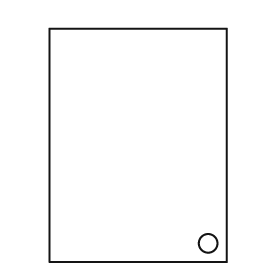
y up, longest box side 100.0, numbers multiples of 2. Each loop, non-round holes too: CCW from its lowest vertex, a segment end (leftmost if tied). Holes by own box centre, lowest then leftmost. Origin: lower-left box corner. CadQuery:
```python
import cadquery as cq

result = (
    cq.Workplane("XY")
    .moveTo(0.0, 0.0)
    .lineTo(76.0, 0.0)
    .lineTo(76.0, 100.0)
    .lineTo(0.0, 100.0)
    .close()
    .moveTo(68.0, 8.0)
    .circle(4.0)
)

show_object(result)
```